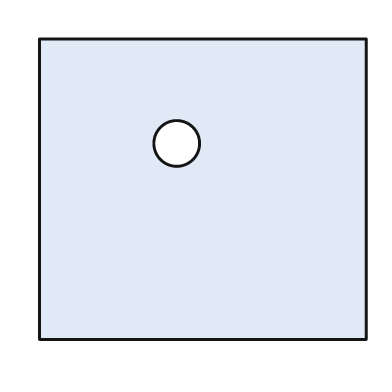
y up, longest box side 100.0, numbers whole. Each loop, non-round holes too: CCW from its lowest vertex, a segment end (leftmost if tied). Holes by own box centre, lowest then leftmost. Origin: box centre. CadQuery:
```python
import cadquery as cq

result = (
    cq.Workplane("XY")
    .moveTo(-50.0, -46.0)
    .lineTo(50.0, -46.0)
    .lineTo(50.0, 46.0)
    .lineTo(-50.0, 46.0)
    .close()
    .moveTo(-8.0, 14.0)
    .circle(7.0)
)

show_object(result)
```